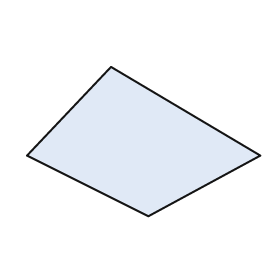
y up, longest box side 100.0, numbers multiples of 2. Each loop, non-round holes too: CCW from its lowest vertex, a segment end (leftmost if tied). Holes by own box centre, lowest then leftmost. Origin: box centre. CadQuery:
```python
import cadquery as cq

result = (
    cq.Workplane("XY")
    .moveTo(2.0, -32.0)
    .lineTo(50.0, -6.0)
    .lineTo(-14.0, 32.0)
    .lineTo(-50.0, -6.0)
    .close()
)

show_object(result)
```